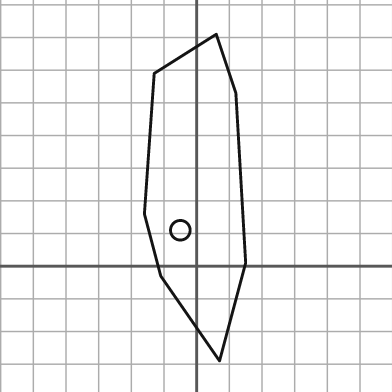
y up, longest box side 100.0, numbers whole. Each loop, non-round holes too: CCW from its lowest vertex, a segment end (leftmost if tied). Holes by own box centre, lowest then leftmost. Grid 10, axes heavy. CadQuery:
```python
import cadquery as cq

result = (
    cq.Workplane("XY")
    .moveTo(7.0, -29.0)
    .lineTo(15.0, 1.0)
    .lineTo(12.0, 53.0)
    .lineTo(6.0, 71.0)
    .lineTo(-13.0, 59.0)
    .lineTo(-16.0, 16.0)
    .lineTo(-11.0, -3.0)
    .close()
    .moveTo(-5.0, 11.0)
    .circle(3.0)
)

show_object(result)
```